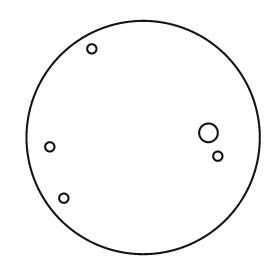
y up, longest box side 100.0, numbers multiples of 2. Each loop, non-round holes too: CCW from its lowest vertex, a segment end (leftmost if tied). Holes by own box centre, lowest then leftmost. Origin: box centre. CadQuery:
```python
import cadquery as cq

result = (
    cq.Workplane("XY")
    .moveTo(0.0, 0.0)
    .circle(50.0)
    .moveTo(-34.0, -26.0)
    .circle(2.0)
    .moveTo(32.0, -8.0)
    .circle(2.0)
    .moveTo(-40.0, -4.0)
    .circle(2.0)
    .moveTo(28.0, 2.0)
    .circle(4.0)
    .moveTo(-22.0, 38.0)
    .circle(2.0)
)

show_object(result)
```